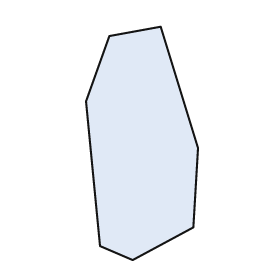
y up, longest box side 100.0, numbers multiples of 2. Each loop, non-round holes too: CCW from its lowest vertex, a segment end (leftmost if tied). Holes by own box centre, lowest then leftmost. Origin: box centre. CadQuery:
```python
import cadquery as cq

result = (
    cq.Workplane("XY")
    .moveTo(-4.0, -50.0)
    .lineTo(22.0, -36.0)
    .lineTo(24.0, -2.0)
    .lineTo(8.0, 50.0)
    .lineTo(-14.0, 46.0)
    .lineTo(-24.0, 18.0)
    .lineTo(-18.0, -44.0)
    .close()
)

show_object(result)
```